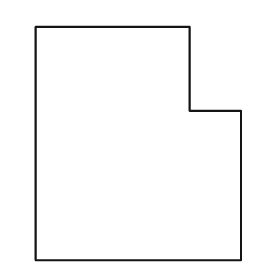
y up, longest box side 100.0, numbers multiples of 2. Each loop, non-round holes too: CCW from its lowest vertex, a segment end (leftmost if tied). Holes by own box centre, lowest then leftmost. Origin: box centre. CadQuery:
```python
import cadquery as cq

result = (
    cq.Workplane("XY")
    .moveTo(-44.0, -50.0)
    .lineTo(44.0, -50.0)
    .lineTo(44.0, 14.0)
    .lineTo(22.0, 14.0)
    .lineTo(22.0, 50.0)
    .lineTo(-44.0, 50.0)
    .close()
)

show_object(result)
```